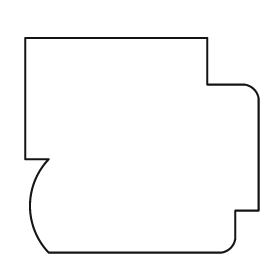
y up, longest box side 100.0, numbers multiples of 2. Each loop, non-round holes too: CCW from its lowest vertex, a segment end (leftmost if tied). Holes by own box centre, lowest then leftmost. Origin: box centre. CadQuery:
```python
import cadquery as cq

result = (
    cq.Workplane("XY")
    .moveTo(-40.0, -46.0)
    .lineTo(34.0, -46.0)
    .threePointArc((38.0, -44.0), (40.0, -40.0))
    .lineTo(40.0, -28.0)
    .lineTo(50.0, -28.0)
    .lineTo(50.0, 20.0)
    .threePointArc((48.0, 24.0), (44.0, 26.0))
    .lineTo(28.0, 26.0)
    .lineTo(28.0, 46.0)
    .lineTo(-50.0, 46.0)
    .lineTo(-50.0, -6.0)
    .lineTo(-40.0, -6.0)
    .threePointArc((-48.0, -26.0), (-40.0, -46.0))
    .close()
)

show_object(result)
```